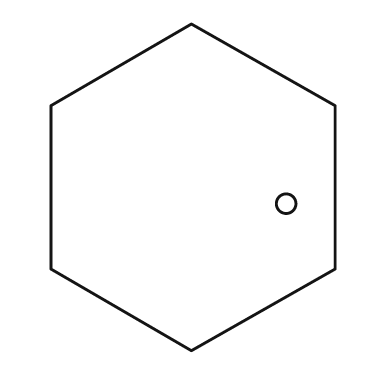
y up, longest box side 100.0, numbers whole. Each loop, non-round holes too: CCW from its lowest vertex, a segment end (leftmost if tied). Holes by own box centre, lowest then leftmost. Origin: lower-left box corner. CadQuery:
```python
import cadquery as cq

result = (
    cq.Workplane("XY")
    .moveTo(43.0, 0.0)
    .lineTo(87.0, 25.0)
    .lineTo(87.0, 75.0)
    .lineTo(43.0, 100.0)
    .lineTo(0.0, 75.0)
    .lineTo(0.0, 25.0)
    .close()
    .moveTo(72.0, 45.0)
    .circle(3.0)
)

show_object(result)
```